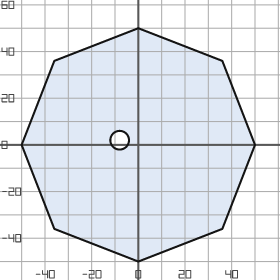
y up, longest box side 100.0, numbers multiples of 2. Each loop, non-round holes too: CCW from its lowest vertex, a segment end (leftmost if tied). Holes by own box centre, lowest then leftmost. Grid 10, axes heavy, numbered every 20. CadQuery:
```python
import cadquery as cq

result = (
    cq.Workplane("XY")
    .moveTo(0.0, -50.0)
    .lineTo(36.0, -36.0)
    .lineTo(50.0, 0.0)
    .lineTo(36.0, 36.0)
    .lineTo(0.0, 50.0)
    .lineTo(-36.0, 36.0)
    .lineTo(-50.0, 0.0)
    .lineTo(-36.0, -36.0)
    .close()
    .moveTo(-8.0, 2.0)
    .circle(4.0)
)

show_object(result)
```